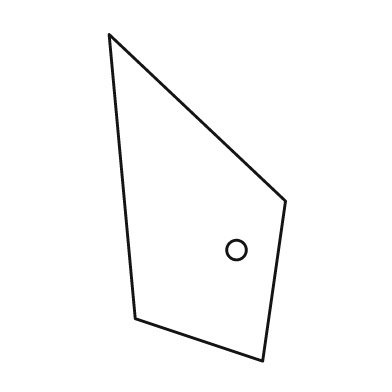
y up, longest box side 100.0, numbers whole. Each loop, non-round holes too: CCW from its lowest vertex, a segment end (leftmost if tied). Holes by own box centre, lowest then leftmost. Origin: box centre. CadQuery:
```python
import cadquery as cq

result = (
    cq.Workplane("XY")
    .moveTo(20.0, -50.0)
    .lineTo(27.0, -1.0)
    .lineTo(-27.0, 50.0)
    .lineTo(-19.0, -37.0)
    .close()
    .moveTo(12.0, -16.0)
    .circle(3.0)
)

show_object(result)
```